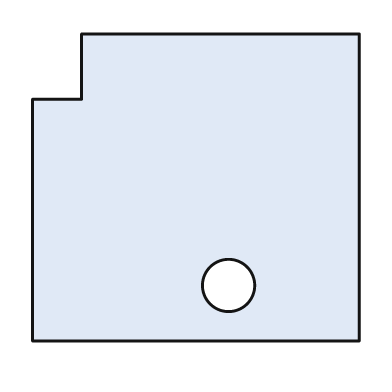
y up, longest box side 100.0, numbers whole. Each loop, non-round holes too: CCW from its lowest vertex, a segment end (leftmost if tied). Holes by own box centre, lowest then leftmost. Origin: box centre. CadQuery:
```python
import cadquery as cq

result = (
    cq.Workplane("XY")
    .moveTo(-50.0, -47.0)
    .lineTo(50.0, -47.0)
    .lineTo(50.0, 47.0)
    .lineTo(-35.0, 47.0)
    .lineTo(-35.0, 27.0)
    .lineTo(-50.0, 27.0)
    .close()
    .moveTo(10.0, -30.0)
    .circle(8.0)
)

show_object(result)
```